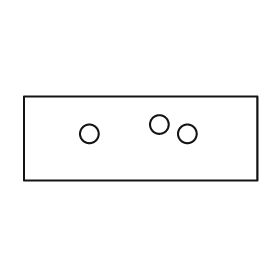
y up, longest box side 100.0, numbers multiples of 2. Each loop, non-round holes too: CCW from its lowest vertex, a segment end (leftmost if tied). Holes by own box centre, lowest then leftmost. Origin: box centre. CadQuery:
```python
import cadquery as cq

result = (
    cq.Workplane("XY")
    .moveTo(-50.0, -18.0)
    .lineTo(50.0, -18.0)
    .lineTo(50.0, 18.0)
    .lineTo(-50.0, 18.0)
    .close()
    .moveTo(-22.0, 2.0)
    .circle(4.0)
    .moveTo(20.0, 2.0)
    .circle(4.0)
    .moveTo(8.0, 6.0)
    .circle(4.0)
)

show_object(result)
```